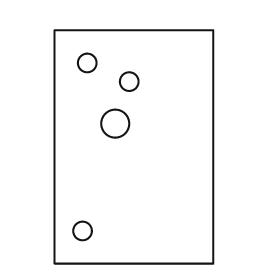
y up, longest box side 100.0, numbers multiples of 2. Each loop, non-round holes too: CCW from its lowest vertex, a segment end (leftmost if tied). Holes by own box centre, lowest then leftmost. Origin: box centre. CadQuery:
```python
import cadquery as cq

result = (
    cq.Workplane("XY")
    .moveTo(-34.0, -50.0)
    .lineTo(34.0, -50.0)
    .lineTo(34.0, 50.0)
    .lineTo(-34.0, 50.0)
    .close()
    .moveTo(-22.0, -36.0)
    .circle(4.0)
    .moveTo(-8.0, 10.0)
    .circle(6.0)
    .moveTo(-2.0, 28.0)
    .circle(4.0)
    .moveTo(-20.0, 36.0)
    .circle(4.0)
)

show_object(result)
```